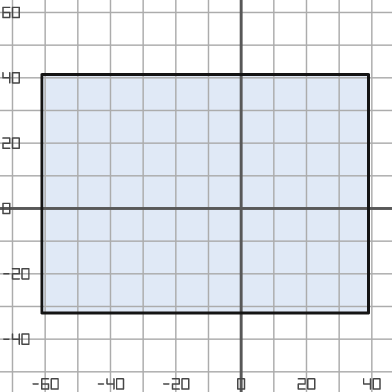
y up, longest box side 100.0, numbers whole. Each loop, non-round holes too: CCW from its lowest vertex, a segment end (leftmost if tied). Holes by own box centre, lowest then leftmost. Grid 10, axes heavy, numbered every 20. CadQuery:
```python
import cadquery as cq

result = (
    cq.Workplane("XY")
    .moveTo(-61.0, -32.0)
    .lineTo(39.0, -32.0)
    .lineTo(39.0, 41.0)
    .lineTo(-61.0, 41.0)
    .close()
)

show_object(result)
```